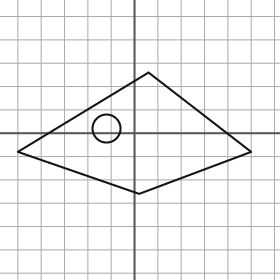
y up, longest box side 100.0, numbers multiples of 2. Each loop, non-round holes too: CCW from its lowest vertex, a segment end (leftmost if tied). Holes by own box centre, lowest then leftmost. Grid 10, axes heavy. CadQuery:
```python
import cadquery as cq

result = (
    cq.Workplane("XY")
    .moveTo(2.0, -26.0)
    .lineTo(50.0, -8.0)
    .lineTo(6.0, 26.0)
    .lineTo(-50.0, -8.0)
    .close()
    .moveTo(-12.0, 2.0)
    .circle(6.0)
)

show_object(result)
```